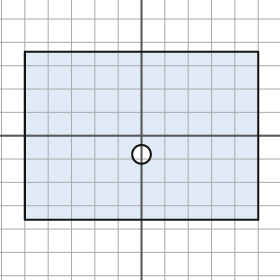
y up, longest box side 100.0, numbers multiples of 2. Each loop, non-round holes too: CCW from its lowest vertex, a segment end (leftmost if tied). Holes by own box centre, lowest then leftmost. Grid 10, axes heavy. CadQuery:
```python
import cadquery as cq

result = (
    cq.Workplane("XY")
    .moveTo(-50.0, -36.0)
    .lineTo(50.0, -36.0)
    .lineTo(50.0, 36.0)
    .lineTo(-50.0, 36.0)
    .close()
    .moveTo(0.0, -8.0)
    .circle(4.0)
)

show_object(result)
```